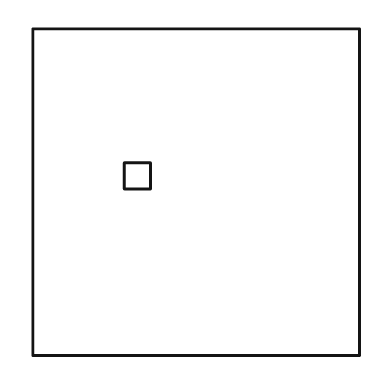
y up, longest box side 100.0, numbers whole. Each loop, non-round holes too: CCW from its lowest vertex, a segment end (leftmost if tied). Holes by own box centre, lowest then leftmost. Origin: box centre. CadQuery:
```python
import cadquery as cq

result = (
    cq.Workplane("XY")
    .moveTo(-50.0, -50.0)
    .lineTo(50.0, -50.0)
    .lineTo(50.0, 50.0)
    .lineTo(-50.0, 50.0)
    .close()
    .moveTo(-22.0, 1.0)
    .lineTo(-14.0, 1.0)
    .lineTo(-14.0, 9.0)
    .lineTo(-22.0, 9.0)
    .close()
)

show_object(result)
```